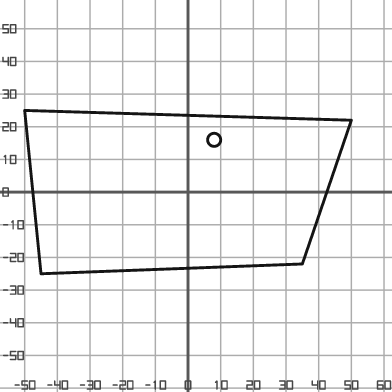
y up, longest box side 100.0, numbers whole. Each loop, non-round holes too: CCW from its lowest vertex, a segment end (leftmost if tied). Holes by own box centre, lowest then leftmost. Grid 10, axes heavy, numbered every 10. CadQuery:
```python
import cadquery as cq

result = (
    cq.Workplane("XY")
    .moveTo(-45.0, -25.0)
    .lineTo(35.0, -22.0)
    .lineTo(50.0, 22.0)
    .lineTo(-50.0, 25.0)
    .close()
    .moveTo(8.0, 16.0)
    .circle(2.0)
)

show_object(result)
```